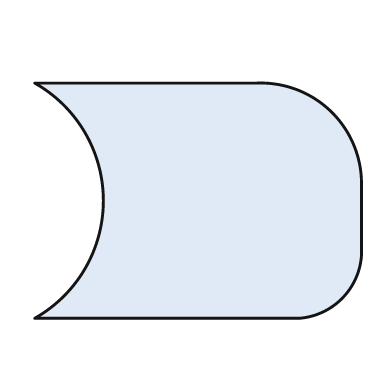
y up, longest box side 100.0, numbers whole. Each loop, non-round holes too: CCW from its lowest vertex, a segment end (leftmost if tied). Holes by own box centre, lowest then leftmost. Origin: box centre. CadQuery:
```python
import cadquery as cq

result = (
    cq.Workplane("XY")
    .moveTo(-50.0, -36.0)
    .lineTo(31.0, -36.0)
    .threePointArc((44.0, -30.0), (50.0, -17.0))
    .lineTo(50.0, 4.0)
    .threePointArc((41.0, 27.0), (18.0, 36.0))
    .lineTo(-50.0, 36.0)
    .threePointArc((-29.0, 0.0), (-50.0, -36.0))
    .close()
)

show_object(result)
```